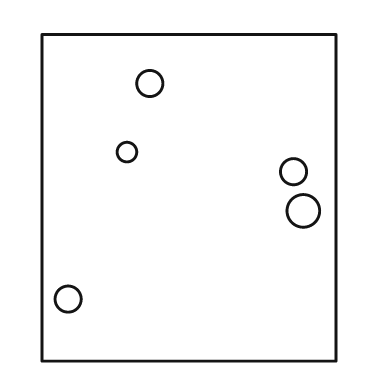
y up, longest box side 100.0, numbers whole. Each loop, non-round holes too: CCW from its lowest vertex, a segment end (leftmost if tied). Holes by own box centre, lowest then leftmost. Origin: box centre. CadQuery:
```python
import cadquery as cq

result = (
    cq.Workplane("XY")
    .moveTo(-45.0, -50.0)
    .lineTo(45.0, -50.0)
    .lineTo(45.0, 50.0)
    .lineTo(-45.0, 50.0)
    .close()
    .moveTo(-37.0, -31.0)
    .circle(4.0)
    .moveTo(35.0, -4.0)
    .circle(5.0)
    .moveTo(32.0, 8.0)
    .circle(4.0)
    .moveTo(-19.0, 14.0)
    .circle(3.0)
    .moveTo(-12.0, 35.0)
    .circle(4.0)
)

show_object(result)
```